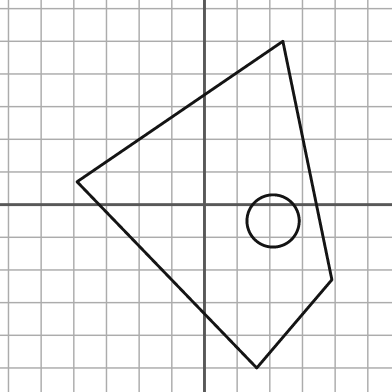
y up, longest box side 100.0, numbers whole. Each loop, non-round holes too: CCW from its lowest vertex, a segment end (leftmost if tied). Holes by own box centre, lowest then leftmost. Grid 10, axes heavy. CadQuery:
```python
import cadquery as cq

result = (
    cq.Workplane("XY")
    .moveTo(16.0, -50.0)
    .lineTo(39.0, -23.0)
    .lineTo(24.0, 50.0)
    .lineTo(-39.0, 7.0)
    .close()
    .moveTo(21.0, -5.0)
    .circle(8.0)
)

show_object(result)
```